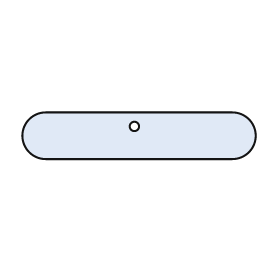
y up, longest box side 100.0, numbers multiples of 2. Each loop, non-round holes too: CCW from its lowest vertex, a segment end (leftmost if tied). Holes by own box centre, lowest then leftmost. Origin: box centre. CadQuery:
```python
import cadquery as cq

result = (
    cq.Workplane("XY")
    .moveTo(-40.0, -10.0)
    .lineTo(40.0, -10.0)
    .threePointArc((50.0, 0.0), (40.0, 10.0))
    .lineTo(-40.0, 10.0)
    .threePointArc((-50.0, 0.0), (-40.0, -10.0))
    .close()
    .moveTo(-2.0, 4.0)
    .circle(2.0)
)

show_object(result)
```